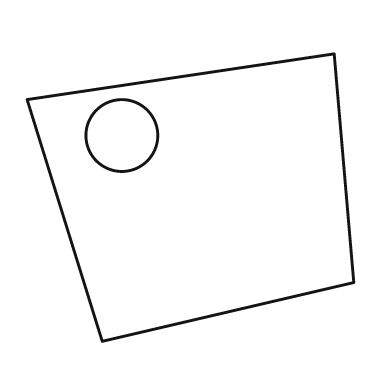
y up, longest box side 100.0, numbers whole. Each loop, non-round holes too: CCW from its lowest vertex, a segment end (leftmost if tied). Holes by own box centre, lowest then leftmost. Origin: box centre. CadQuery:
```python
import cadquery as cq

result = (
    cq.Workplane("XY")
    .moveTo(-27.0, -44.0)
    .lineTo(50.0, -26.0)
    .lineTo(44.0, 44.0)
    .lineTo(-50.0, 30.0)
    .close()
    .moveTo(-21.0, 19.0)
    .circle(11.0)
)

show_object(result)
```